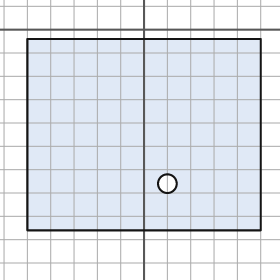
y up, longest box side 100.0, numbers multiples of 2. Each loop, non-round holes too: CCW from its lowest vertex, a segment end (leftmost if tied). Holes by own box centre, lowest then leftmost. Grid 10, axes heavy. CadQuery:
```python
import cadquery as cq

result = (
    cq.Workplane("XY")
    .moveTo(-50.0, -86.0)
    .lineTo(50.0, -86.0)
    .lineTo(50.0, -4.0)
    .lineTo(-50.0, -4.0)
    .close()
    .moveTo(10.0, -66.0)
    .circle(4.0)
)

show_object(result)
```